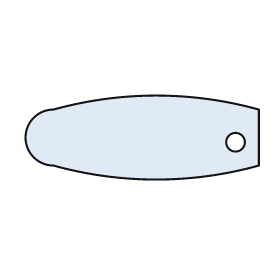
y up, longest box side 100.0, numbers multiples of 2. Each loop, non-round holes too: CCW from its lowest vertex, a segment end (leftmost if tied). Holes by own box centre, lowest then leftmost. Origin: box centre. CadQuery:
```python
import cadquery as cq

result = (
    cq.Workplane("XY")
    .moveTo(-38.0, -12.0)
    .threePointArc((6.0, -18.0), (50.0, -12.0))
    .lineTo(50.0, 12.0)
    .threePointArc((6.0, 18.0), (-38.0, 12.0))
    .threePointArc((-50.0, 0.0), (-38.0, -12.0))
    .close()
    .moveTo(40.0, -2.0)
    .circle(4.0)
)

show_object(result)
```